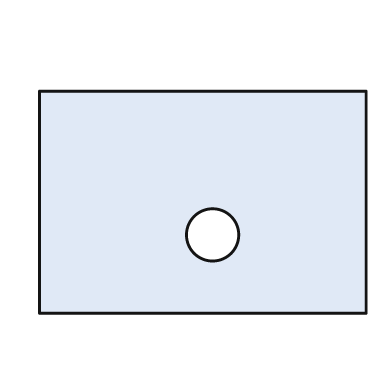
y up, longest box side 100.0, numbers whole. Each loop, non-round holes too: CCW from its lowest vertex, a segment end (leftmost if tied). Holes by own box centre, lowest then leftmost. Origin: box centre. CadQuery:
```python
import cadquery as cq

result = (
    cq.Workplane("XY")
    .moveTo(-50.0, -34.0)
    .lineTo(50.0, -34.0)
    .lineTo(50.0, 34.0)
    .lineTo(-50.0, 34.0)
    .close()
    .moveTo(3.0, -10.0)
    .circle(8.0)
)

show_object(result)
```